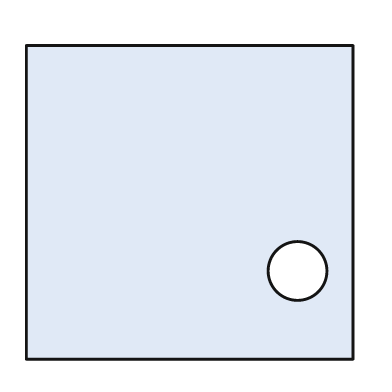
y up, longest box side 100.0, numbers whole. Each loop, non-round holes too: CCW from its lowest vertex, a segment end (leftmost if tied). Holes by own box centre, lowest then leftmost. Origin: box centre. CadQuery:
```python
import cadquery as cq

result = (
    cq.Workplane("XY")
    .moveTo(-50.0, -48.0)
    .lineTo(50.0, -48.0)
    .lineTo(50.0, 48.0)
    .lineTo(-50.0, 48.0)
    .close()
    .moveTo(33.0, -21.0)
    .circle(9.0)
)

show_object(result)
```